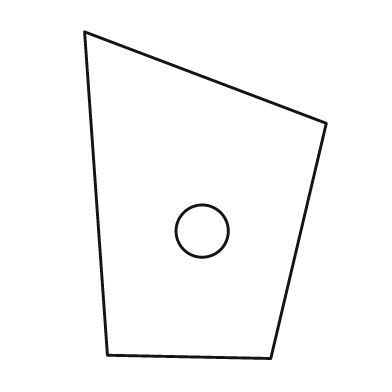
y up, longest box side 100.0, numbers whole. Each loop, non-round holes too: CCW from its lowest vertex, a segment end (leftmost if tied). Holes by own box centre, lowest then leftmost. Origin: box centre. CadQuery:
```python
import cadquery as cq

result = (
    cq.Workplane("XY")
    .moveTo(20.0, -50.0)
    .lineTo(37.0, 22.0)
    .lineTo(-37.0, 50.0)
    .lineTo(-30.0, -49.0)
    .close()
    .moveTo(-1.0, -11.0)
    .circle(8.0)
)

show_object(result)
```